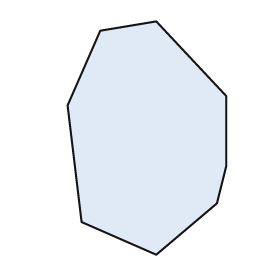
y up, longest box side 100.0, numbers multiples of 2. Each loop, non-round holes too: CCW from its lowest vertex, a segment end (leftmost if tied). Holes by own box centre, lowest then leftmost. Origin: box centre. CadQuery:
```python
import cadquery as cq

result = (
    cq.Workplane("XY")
    .moveTo(4.0, -50.0)
    .lineTo(30.0, -28.0)
    .lineTo(34.0, -12.0)
    .lineTo(34.0, 18.0)
    .lineTo(4.0, 50.0)
    .lineTo(-20.0, 46.0)
    .lineTo(-34.0, 14.0)
    .lineTo(-28.0, -36.0)
    .close()
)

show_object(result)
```